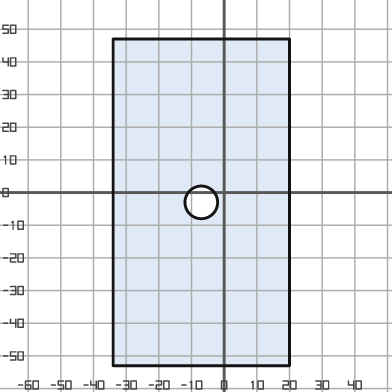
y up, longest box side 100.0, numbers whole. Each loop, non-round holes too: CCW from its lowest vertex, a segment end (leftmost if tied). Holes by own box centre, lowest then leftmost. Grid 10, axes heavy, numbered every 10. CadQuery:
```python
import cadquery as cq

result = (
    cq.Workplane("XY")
    .moveTo(-34.0, -53.0)
    .lineTo(20.0, -53.0)
    .lineTo(20.0, 47.0)
    .lineTo(-34.0, 47.0)
    .close()
    .moveTo(-7.0, -3.0)
    .circle(5.0)
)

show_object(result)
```